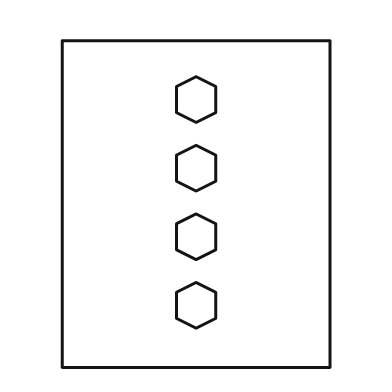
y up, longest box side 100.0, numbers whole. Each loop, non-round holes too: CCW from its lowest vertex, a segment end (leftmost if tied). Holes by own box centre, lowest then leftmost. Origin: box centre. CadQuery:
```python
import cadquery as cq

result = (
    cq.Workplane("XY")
    .moveTo(-41.0, -50.0)
    .lineTo(41.0, -50.0)
    .lineTo(41.0, 50.0)
    .lineTo(-41.0, 50.0)
    .close()
    .moveTo(0.0, -38.0)
    .lineTo(6.0, -35.0)
    .lineTo(6.0, -27.0)
    .lineTo(0.0, -24.0)
    .lineTo(-6.0, -27.0)
    .lineTo(-6.0, -35.0)
    .close()
    .moveTo(0.0, -17.0)
    .lineTo(6.0, -14.0)
    .lineTo(6.0, -6.0)
    .lineTo(0.0, -3.0)
    .lineTo(-6.0, -6.0)
    .lineTo(-6.0, -14.0)
    .close()
    .moveTo(0.0, 4.0)
    .lineTo(6.0, 7.0)
    .lineTo(6.0, 15.0)
    .lineTo(0.0, 18.0)
    .lineTo(-6.0, 15.0)
    .lineTo(-6.0, 7.0)
    .close()
    .moveTo(0.0, 25.0)
    .lineTo(6.0, 28.0)
    .lineTo(6.0, 36.0)
    .lineTo(0.0, 39.0)
    .lineTo(-6.0, 36.0)
    .lineTo(-6.0, 28.0)
    .close()
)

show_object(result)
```